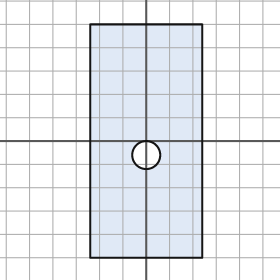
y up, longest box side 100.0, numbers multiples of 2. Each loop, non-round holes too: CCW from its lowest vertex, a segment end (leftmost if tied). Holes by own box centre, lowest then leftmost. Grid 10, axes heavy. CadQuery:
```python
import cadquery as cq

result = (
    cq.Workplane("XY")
    .moveTo(-24.0, -50.0)
    .lineTo(24.0, -50.0)
    .lineTo(24.0, 50.0)
    .lineTo(-24.0, 50.0)
    .close()
    .moveTo(0.0, -6.0)
    .circle(6.0)
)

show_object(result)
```